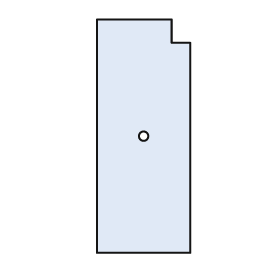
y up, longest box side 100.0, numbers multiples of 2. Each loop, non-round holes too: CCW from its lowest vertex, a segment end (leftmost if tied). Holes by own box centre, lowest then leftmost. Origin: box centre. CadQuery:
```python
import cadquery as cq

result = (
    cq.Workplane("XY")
    .moveTo(-20.0, -50.0)
    .lineTo(20.0, -50.0)
    .lineTo(20.0, 40.0)
    .lineTo(12.0, 40.0)
    .lineTo(12.0, 50.0)
    .lineTo(-20.0, 50.0)
    .close()
    .moveTo(0.0, 0.0)
    .circle(2.0)
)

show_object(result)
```